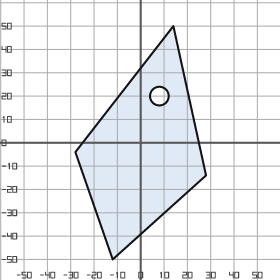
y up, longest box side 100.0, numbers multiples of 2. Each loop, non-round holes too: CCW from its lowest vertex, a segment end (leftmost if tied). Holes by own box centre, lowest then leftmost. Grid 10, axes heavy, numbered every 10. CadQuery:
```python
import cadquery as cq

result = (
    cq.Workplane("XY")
    .moveTo(-12.0, -50.0)
    .lineTo(28.0, -14.0)
    .lineTo(14.0, 50.0)
    .lineTo(-28.0, -4.0)
    .close()
    .moveTo(8.0, 20.0)
    .circle(4.0)
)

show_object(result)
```